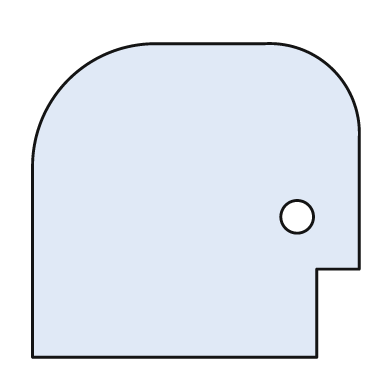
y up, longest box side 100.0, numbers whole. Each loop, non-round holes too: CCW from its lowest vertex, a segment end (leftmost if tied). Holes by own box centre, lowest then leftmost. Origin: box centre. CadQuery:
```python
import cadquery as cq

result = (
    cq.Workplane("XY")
    .moveTo(-50.0, -48.0)
    .lineTo(37.0, -48.0)
    .lineTo(37.0, -21.0)
    .lineTo(50.0, -21.0)
    .lineTo(50.0, 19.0)
    .threePointArc((42.0, 40.0), (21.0, 48.0))
    .lineTo(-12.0, 48.0)
    .threePointArc((-39.0, 37.0), (-50.0, 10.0))
    .close()
    .moveTo(31.0, -5.0)
    .circle(5.0)
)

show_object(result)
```